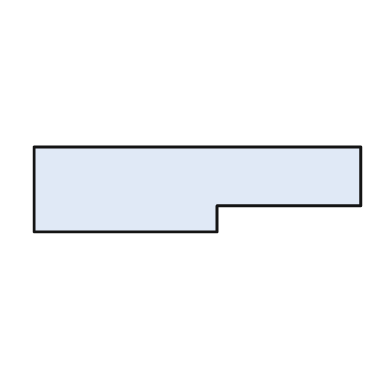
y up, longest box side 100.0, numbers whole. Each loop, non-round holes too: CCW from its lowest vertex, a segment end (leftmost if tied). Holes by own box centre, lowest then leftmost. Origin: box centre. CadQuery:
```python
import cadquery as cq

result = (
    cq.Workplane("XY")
    .moveTo(-50.0, -13.0)
    .lineTo(6.0, -13.0)
    .lineTo(6.0, -5.0)
    .lineTo(50.0, -5.0)
    .lineTo(50.0, 13.0)
    .lineTo(-50.0, 13.0)
    .close()
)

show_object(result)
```